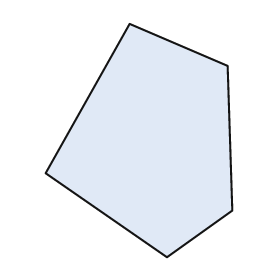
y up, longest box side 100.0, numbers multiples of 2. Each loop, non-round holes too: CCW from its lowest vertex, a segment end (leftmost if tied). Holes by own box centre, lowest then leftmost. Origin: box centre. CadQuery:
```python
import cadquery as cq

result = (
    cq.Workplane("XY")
    .moveTo(12.0, -50.0)
    .lineTo(40.0, -30.0)
    .lineTo(38.0, 32.0)
    .lineTo(-4.0, 50.0)
    .lineTo(-40.0, -14.0)
    .close()
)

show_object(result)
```